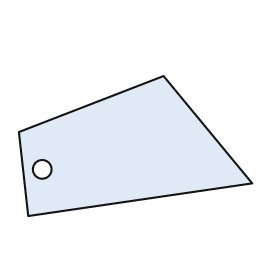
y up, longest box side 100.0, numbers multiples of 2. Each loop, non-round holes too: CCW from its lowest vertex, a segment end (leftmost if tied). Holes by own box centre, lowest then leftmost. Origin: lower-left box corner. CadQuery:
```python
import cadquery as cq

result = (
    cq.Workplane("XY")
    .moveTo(4.0, 0.0)
    .lineTo(100.0, 14.0)
    .lineTo(62.0, 60.0)
    .lineTo(0.0, 36.0)
    .close()
    .moveTo(10.0, 20.0)
    .circle(4.0)
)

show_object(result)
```